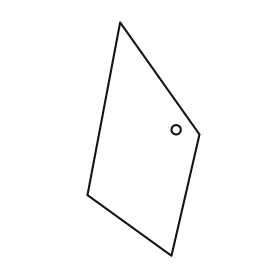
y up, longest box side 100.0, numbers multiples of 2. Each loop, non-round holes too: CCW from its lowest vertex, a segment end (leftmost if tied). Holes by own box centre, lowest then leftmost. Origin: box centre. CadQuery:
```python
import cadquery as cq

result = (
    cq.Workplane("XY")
    .moveTo(12.0, -50.0)
    .lineTo(24.0, 2.0)
    .lineTo(-10.0, 50.0)
    .lineTo(-24.0, -24.0)
    .close()
    .moveTo(14.0, 4.0)
    .circle(2.0)
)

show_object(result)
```